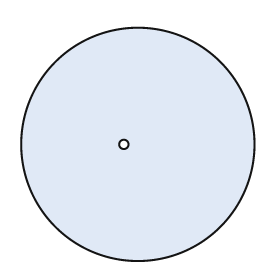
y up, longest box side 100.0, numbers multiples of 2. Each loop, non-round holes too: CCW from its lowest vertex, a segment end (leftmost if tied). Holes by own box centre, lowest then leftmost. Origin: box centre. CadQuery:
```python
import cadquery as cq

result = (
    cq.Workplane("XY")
    .moveTo(0.0, 0.0)
    .circle(50.0)
    .moveTo(-6.0, 0.0)
    .circle(2.0)
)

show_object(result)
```